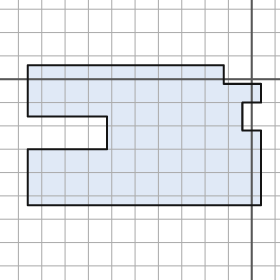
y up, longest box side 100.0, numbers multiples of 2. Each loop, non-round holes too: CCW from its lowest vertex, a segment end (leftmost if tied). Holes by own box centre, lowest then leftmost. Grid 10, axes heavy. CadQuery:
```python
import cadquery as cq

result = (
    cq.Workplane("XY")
    .moveTo(-96.0, -54.0)
    .lineTo(4.0, -54.0)
    .lineTo(4.0, -22.0)
    .lineTo(-4.0, -22.0)
    .lineTo(-4.0, -10.0)
    .lineTo(4.0, -10.0)
    .lineTo(4.0, -2.0)
    .lineTo(-12.0, -2.0)
    .lineTo(-12.0, 6.0)
    .lineTo(-96.0, 6.0)
    .lineTo(-96.0, -16.0)
    .lineTo(-62.0, -16.0)
    .lineTo(-62.0, -30.0)
    .lineTo(-96.0, -30.0)
    .close()
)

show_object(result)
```